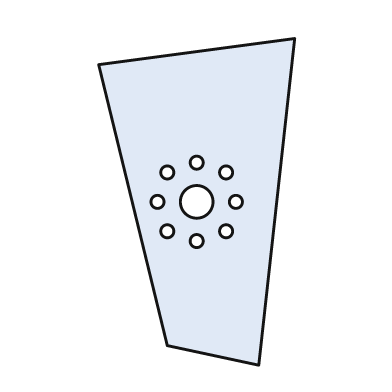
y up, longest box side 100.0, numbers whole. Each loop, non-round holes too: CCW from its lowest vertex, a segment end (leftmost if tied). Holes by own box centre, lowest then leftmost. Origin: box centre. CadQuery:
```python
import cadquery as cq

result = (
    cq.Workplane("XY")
    .moveTo(19.0, -50.0)
    .lineTo(30.0, 50.0)
    .lineTo(-30.0, 42.0)
    .lineTo(-9.0, -44.0)
    .close()
    .moveTo(0.0, -12.0)
    .circle(2.0)
    .moveTo(-9.0, -9.0)
    .circle(2.0)
    .moveTo(9.0, -9.0)
    .circle(2.0)
    .moveTo(-12.0, 0.0)
    .circle(2.0)
    .moveTo(0.0, 0.0)
    .circle(5.0)
    .moveTo(12.0, 0.0)
    .circle(2.0)
    .moveTo(-9.0, 9.0)
    .circle(2.0)
    .moveTo(9.0, 9.0)
    .circle(2.0)
    .moveTo(0.0, 12.0)
    .circle(2.0)
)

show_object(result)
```